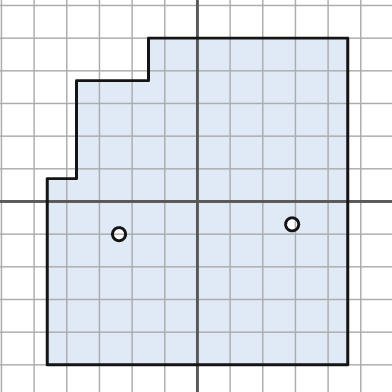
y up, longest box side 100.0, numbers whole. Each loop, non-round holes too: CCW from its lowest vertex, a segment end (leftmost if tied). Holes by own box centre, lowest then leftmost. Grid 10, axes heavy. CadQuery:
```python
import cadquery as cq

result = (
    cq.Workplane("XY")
    .moveTo(-46.0, -50.0)
    .lineTo(46.0, -50.0)
    .lineTo(46.0, 50.0)
    .lineTo(-15.0, 50.0)
    .lineTo(-15.0, 37.0)
    .lineTo(-37.0, 37.0)
    .lineTo(-37.0, 7.0)
    .lineTo(-46.0, 7.0)
    .close()
    .moveTo(-24.0, -10.0)
    .circle(2.0)
    .moveTo(29.0, -7.0)
    .circle(2.0)
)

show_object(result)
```